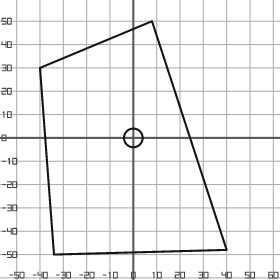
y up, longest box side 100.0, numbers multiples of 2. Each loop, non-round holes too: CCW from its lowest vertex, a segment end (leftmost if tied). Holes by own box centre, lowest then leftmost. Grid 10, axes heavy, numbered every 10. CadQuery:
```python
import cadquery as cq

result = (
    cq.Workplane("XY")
    .moveTo(-34.0, -50.0)
    .lineTo(40.0, -48.0)
    .lineTo(8.0, 50.0)
    .lineTo(-40.0, 30.0)
    .close()
    .moveTo(0.0, 0.0)
    .circle(4.0)
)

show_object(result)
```